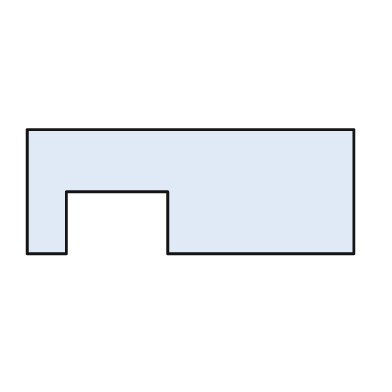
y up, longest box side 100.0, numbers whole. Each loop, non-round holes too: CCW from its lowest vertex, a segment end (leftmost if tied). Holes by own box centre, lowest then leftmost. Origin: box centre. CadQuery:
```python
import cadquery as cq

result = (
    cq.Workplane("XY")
    .moveTo(-50.0, -19.0)
    .lineTo(-38.0, -19.0)
    .lineTo(-38.0, 0.0)
    .lineTo(-7.0, 0.0)
    .lineTo(-7.0, -19.0)
    .lineTo(50.0, -19.0)
    .lineTo(50.0, 19.0)
    .lineTo(-50.0, 19.0)
    .close()
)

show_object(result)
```